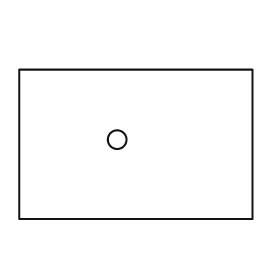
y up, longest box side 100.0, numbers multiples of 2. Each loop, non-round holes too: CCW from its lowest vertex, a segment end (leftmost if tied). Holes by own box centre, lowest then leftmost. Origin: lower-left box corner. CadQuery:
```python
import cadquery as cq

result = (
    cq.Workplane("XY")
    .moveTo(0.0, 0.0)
    .lineTo(100.0, 0.0)
    .lineTo(100.0, 64.0)
    .lineTo(0.0, 64.0)
    .close()
    .moveTo(42.0, 34.0)
    .circle(4.0)
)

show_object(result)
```